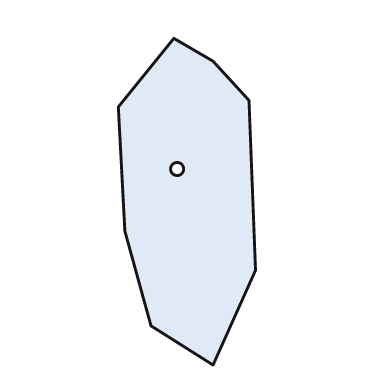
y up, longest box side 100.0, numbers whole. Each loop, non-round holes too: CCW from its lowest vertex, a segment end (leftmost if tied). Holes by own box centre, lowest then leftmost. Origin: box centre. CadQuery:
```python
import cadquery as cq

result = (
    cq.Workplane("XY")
    .moveTo(8.0, -50.0)
    .lineTo(21.0, -21.0)
    .lineTo(19.0, 31.0)
    .lineTo(8.0, 43.0)
    .lineTo(-4.0, 50.0)
    .lineTo(-21.0, 29.0)
    .lineTo(-19.0, -9.0)
    .lineTo(-11.0, -38.0)
    .close()
    .moveTo(-3.0, 10.0)
    .circle(2.0)
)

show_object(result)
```